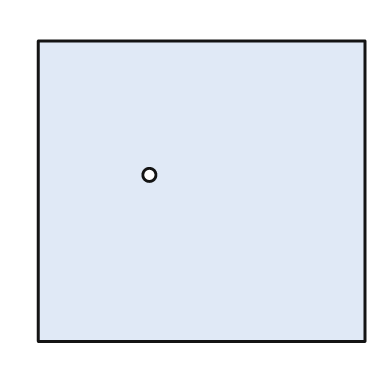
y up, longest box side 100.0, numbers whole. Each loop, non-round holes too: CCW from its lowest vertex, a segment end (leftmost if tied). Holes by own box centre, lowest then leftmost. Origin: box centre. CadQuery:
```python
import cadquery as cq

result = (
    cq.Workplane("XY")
    .moveTo(-50.0, -46.0)
    .lineTo(50.0, -46.0)
    .lineTo(50.0, 46.0)
    .lineTo(-50.0, 46.0)
    .close()
    .moveTo(-16.0, 5.0)
    .circle(2.0)
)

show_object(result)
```